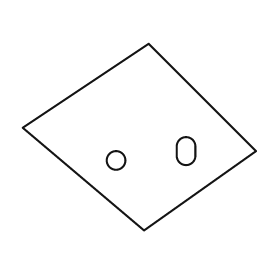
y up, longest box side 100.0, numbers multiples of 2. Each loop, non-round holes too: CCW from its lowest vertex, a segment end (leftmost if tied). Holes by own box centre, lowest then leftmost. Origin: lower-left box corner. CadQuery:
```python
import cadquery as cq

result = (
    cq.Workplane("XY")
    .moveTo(52.0, 0.0)
    .lineTo(100.0, 34.0)
    .lineTo(54.0, 80.0)
    .lineTo(0.0, 44.0)
    .close()
    .moveTo(40.0, 30.0)
    .circle(4.0)
    .moveTo(66.0, 32.0)
    .threePointArc((70.0, 28.0), (74.0, 32.0))
    .lineTo(74.0, 36.0)
    .threePointArc((70.0, 40.0), (66.0, 36.0))
    .close()
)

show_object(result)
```